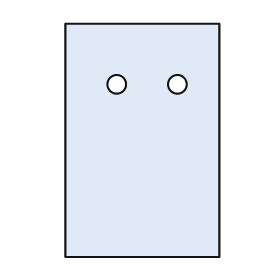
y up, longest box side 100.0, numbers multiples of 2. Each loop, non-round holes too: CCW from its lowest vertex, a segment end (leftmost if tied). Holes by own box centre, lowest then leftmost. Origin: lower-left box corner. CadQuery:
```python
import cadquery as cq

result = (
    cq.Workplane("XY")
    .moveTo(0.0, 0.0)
    .lineTo(66.0, 0.0)
    .lineTo(66.0, 100.0)
    .lineTo(0.0, 100.0)
    .close()
    .moveTo(22.0, 74.0)
    .circle(4.0)
    .moveTo(48.0, 74.0)
    .circle(4.0)
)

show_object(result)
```